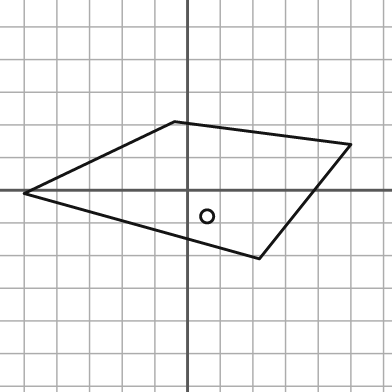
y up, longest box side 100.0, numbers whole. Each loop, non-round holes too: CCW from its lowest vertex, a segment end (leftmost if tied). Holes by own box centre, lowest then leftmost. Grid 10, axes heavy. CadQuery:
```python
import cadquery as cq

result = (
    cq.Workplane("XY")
    .moveTo(22.0, -21.0)
    .lineTo(50.0, 14.0)
    .lineTo(-4.0, 21.0)
    .lineTo(-50.0, -1.0)
    .close()
    .moveTo(6.0, -8.0)
    .circle(2.0)
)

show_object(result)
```